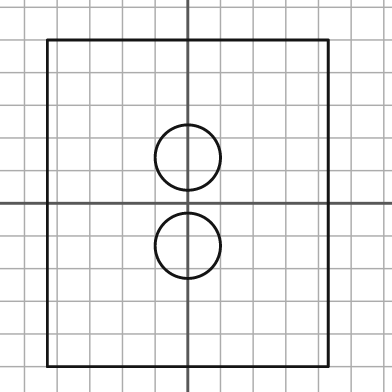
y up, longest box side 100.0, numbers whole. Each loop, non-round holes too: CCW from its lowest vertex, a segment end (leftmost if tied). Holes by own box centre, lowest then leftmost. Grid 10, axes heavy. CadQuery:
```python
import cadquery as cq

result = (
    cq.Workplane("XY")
    .moveTo(-43.0, -50.0)
    .lineTo(43.0, -50.0)
    .lineTo(43.0, 50.0)
    .lineTo(-43.0, 50.0)
    .close()
    .moveTo(0.0, -13.0)
    .circle(10.0)
    .moveTo(0.0, 14.0)
    .circle(10.0)
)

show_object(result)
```